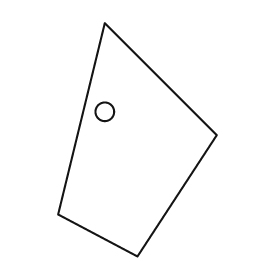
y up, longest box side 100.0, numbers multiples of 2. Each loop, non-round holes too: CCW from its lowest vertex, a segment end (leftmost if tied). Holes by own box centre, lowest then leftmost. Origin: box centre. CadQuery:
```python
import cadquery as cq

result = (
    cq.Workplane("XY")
    .moveTo(0.0, -50.0)
    .lineTo(34.0, 2.0)
    .lineTo(-14.0, 50.0)
    .lineTo(-34.0, -32.0)
    .close()
    .moveTo(-14.0, 12.0)
    .circle(4.0)
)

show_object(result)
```